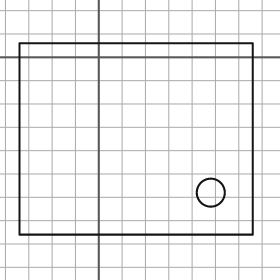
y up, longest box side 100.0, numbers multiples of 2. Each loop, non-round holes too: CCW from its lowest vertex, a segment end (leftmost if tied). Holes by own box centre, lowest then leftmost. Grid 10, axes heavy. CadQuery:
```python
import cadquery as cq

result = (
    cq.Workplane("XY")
    .moveTo(-34.0, -76.0)
    .lineTo(66.0, -76.0)
    .lineTo(66.0, 6.0)
    .lineTo(-34.0, 6.0)
    .close()
    .moveTo(48.0, -58.0)
    .circle(6.0)
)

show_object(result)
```